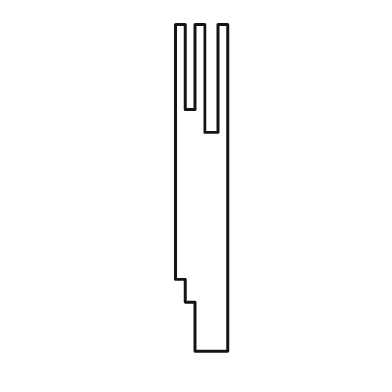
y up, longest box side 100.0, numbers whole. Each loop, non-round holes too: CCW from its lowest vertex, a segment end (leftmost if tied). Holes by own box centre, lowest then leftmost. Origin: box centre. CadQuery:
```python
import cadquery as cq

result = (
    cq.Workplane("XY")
    .moveTo(-2.0, -50.0)
    .lineTo(8.0, -50.0)
    .lineTo(8.0, 50.0)
    .lineTo(5.0, 50.0)
    .lineTo(5.0, 17.0)
    .lineTo(1.0, 17.0)
    .lineTo(1.0, 50.0)
    .lineTo(-2.0, 50.0)
    .lineTo(-2.0, 24.0)
    .lineTo(-5.0, 24.0)
    .lineTo(-5.0, 50.0)
    .lineTo(-8.0, 50.0)
    .lineTo(-8.0, -28.0)
    .lineTo(-5.0, -28.0)
    .lineTo(-5.0, -35.0)
    .lineTo(-2.0, -35.0)
    .close()
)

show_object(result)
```